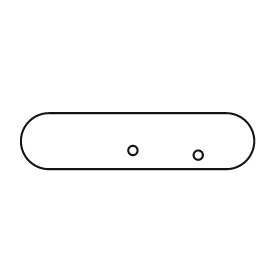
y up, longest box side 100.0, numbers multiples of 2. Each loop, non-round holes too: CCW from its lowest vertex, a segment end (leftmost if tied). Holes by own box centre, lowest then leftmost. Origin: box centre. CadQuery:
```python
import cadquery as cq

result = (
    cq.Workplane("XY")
    .moveTo(-38.0, -12.0)
    .lineTo(38.0, -12.0)
    .threePointArc((50.0, 0.0), (38.0, 12.0))
    .lineTo(-38.0, 12.0)
    .threePointArc((-50.0, 0.0), (-38.0, -12.0))
    .close()
    .moveTo(26.0, -6.0)
    .circle(2.0)
    .moveTo(-2.0, -4.0)
    .circle(2.0)
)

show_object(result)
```